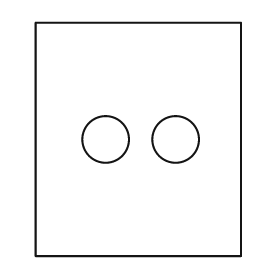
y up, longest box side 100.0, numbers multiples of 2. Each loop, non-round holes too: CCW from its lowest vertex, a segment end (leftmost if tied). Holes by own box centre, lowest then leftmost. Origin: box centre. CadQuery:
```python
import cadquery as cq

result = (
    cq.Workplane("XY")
    .moveTo(-44.0, -50.0)
    .lineTo(44.0, -50.0)
    .lineTo(44.0, 50.0)
    .lineTo(-44.0, 50.0)
    .close()
    .moveTo(-14.0, 0.0)
    .circle(10.0)
    .moveTo(16.0, 0.0)
    .circle(10.0)
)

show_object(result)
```